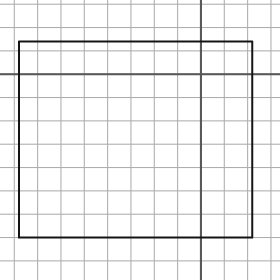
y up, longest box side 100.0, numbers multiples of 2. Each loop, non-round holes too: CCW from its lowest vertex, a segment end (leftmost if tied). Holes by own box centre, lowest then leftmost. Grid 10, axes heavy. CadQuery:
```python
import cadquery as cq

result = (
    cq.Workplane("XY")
    .moveTo(-78.0, -70.0)
    .lineTo(22.0, -70.0)
    .lineTo(22.0, 14.0)
    .lineTo(-78.0, 14.0)
    .close()
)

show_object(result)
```